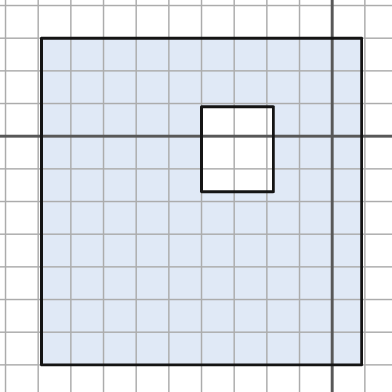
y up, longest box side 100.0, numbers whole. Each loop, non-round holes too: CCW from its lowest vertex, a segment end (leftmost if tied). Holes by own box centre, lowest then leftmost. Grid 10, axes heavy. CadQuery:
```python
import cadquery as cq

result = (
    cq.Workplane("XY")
    .moveTo(-89.0, -70.0)
    .lineTo(9.0, -70.0)
    .lineTo(9.0, 30.0)
    .lineTo(-89.0, 30.0)
    .close()
    .moveTo(-40.0, -17.0)
    .lineTo(-18.0, -17.0)
    .lineTo(-18.0, 9.0)
    .lineTo(-40.0, 9.0)
    .close()
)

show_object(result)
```